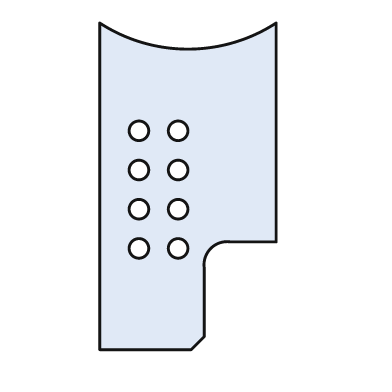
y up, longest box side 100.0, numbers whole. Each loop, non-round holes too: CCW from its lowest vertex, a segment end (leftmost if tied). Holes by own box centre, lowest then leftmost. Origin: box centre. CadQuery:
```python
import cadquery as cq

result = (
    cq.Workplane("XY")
    .moveTo(-27.0, -50.0)
    .lineTo(1.0, -50.0)
    .lineTo(5.0, -46.0)
    .lineTo(5.0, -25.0)
    .threePointArc((7.0, -19.0), (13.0, -17.0))
    .lineTo(27.0, -17.0)
    .lineTo(27.0, 50.0)
    .threePointArc((0.0, 42.0), (-27.0, 50.0))
    .close()
    .moveTo(-15.0, -19.0)
    .circle(3.0)
    .moveTo(-3.0, -19.0)
    .circle(3.0)
    .moveTo(-15.0, -7.0)
    .circle(3.0)
    .moveTo(-3.0, -7.0)
    .circle(3.0)
    .moveTo(-15.0, 5.0)
    .circle(3.0)
    .moveTo(-3.0, 5.0)
    .circle(3.0)
    .moveTo(-15.0, 17.0)
    .circle(3.0)
    .moveTo(-3.0, 17.0)
    .circle(3.0)
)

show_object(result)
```